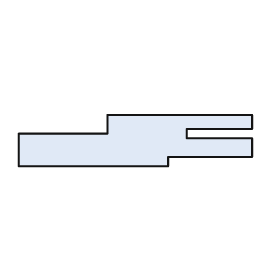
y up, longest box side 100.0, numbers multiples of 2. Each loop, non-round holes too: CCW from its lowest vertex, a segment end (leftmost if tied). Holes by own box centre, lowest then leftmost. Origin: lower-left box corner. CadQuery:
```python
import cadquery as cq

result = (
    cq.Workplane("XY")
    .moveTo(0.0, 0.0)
    .lineTo(64.0, 0.0)
    .lineTo(64.0, 4.0)
    .lineTo(100.0, 4.0)
    .lineTo(100.0, 12.0)
    .lineTo(72.0, 12.0)
    .lineTo(72.0, 16.0)
    .lineTo(100.0, 16.0)
    .lineTo(100.0, 22.0)
    .lineTo(38.0, 22.0)
    .lineTo(38.0, 14.0)
    .lineTo(0.0, 14.0)
    .close()
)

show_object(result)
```